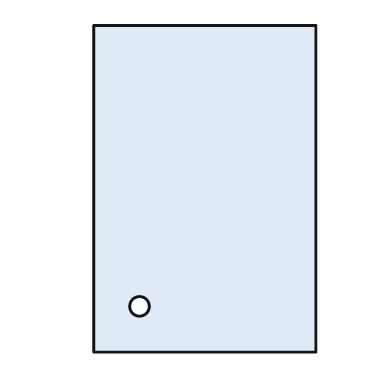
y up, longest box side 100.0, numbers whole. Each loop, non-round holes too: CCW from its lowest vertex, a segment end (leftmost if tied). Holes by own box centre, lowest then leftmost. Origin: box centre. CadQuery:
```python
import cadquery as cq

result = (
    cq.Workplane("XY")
    .moveTo(-34.0, -50.0)
    .lineTo(34.0, -50.0)
    .lineTo(34.0, 50.0)
    .lineTo(-34.0, 50.0)
    .close()
    .moveTo(-20.0, -36.0)
    .circle(3.0)
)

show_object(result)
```